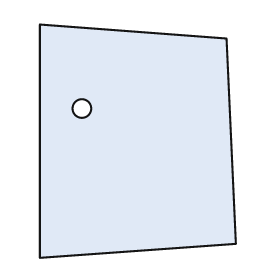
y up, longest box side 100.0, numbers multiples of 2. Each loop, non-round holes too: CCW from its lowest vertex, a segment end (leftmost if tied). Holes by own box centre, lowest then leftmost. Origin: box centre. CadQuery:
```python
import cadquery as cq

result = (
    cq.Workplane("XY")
    .moveTo(-42.0, -50.0)
    .lineTo(42.0, -44.0)
    .lineTo(38.0, 44.0)
    .lineTo(-42.0, 50.0)
    .close()
    .moveTo(-24.0, 14.0)
    .circle(4.0)
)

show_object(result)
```